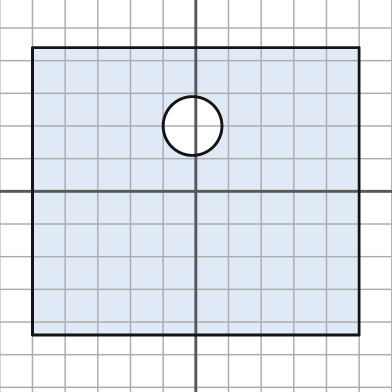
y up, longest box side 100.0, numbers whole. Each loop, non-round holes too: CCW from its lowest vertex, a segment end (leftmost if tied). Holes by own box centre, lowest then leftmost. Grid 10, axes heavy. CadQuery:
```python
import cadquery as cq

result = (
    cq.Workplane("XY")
    .moveTo(-50.0, -44.0)
    .lineTo(50.0, -44.0)
    .lineTo(50.0, 44.0)
    .lineTo(-50.0, 44.0)
    .close()
    .moveTo(-1.0, 20.0)
    .circle(9.0)
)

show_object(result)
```